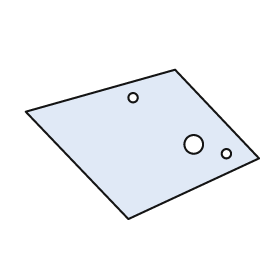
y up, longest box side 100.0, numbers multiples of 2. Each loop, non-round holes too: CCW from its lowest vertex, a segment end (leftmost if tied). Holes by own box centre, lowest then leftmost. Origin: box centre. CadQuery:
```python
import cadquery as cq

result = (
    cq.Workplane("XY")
    .moveTo(-6.0, -32.0)
    .lineTo(50.0, -6.0)
    .lineTo(14.0, 32.0)
    .lineTo(-50.0, 14.0)
    .close()
    .moveTo(36.0, -4.0)
    .circle(2.0)
    .moveTo(22.0, 0.0)
    .circle(4.0)
    .moveTo(-4.0, 20.0)
    .circle(2.0)
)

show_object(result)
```